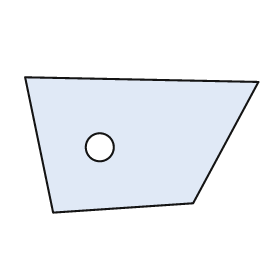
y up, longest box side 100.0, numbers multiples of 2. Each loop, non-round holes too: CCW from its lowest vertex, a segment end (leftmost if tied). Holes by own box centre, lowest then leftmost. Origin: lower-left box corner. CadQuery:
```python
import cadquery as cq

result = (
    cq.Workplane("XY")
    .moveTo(12.0, 0.0)
    .lineTo(72.0, 4.0)
    .lineTo(100.0, 56.0)
    .lineTo(0.0, 58.0)
    .close()
    .moveTo(32.0, 28.0)
    .circle(6.0)
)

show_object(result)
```